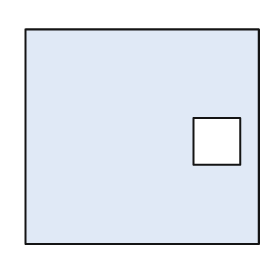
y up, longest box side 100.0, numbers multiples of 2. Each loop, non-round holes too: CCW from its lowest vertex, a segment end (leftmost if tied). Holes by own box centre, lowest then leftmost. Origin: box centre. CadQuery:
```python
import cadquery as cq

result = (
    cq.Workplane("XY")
    .moveTo(-50.0, -46.0)
    .lineTo(50.0, -46.0)
    .lineTo(50.0, 46.0)
    .lineTo(-50.0, 46.0)
    .close()
    .moveTo(22.0, -12.0)
    .lineTo(42.0, -12.0)
    .lineTo(42.0, 8.0)
    .lineTo(22.0, 8.0)
    .close()
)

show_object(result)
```